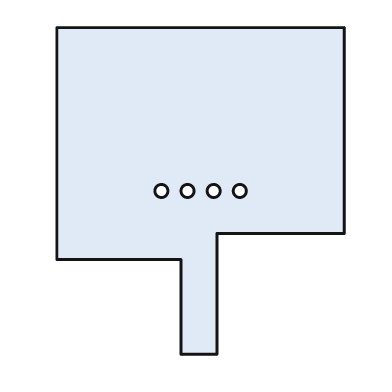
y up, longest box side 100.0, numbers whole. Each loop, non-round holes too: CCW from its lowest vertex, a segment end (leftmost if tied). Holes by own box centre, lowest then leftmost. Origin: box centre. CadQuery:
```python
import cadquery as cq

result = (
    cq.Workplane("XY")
    .moveTo(-6.0, -50.0)
    .lineTo(5.0, -50.0)
    .lineTo(5.0, -13.0)
    .lineTo(44.0, -13.0)
    .lineTo(44.0, 50.0)
    .lineTo(-44.0, 50.0)
    .lineTo(-44.0, -21.0)
    .lineTo(-6.0, -21.0)
    .close()
    .moveTo(-12.0, 0.0)
    .circle(2.0)
    .moveTo(-4.0, 0.0)
    .circle(2.0)
    .moveTo(4.0, 0.0)
    .circle(2.0)
    .moveTo(12.0, 0.0)
    .circle(2.0)
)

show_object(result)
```